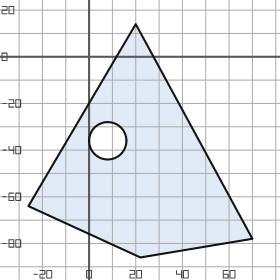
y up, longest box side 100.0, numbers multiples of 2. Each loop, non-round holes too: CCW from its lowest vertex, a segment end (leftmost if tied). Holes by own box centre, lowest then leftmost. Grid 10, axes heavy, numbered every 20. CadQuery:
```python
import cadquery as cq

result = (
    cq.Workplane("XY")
    .moveTo(22.0, -86.0)
    .lineTo(70.0, -78.0)
    .lineTo(20.0, 14.0)
    .lineTo(-26.0, -64.0)
    .close()
    .moveTo(8.0, -36.0)
    .circle(8.0)
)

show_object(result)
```